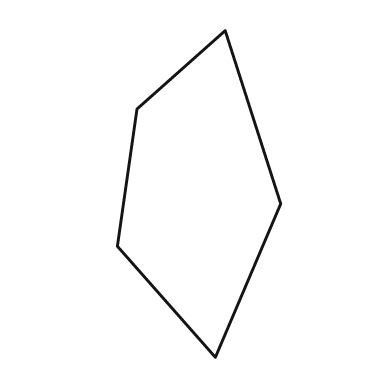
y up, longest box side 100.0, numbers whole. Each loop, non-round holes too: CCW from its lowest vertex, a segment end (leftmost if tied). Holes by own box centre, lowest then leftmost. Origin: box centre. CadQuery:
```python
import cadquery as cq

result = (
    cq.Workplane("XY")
    .moveTo(5.0, -50.0)
    .lineTo(25.0, -3.0)
    .lineTo(8.0, 50.0)
    .lineTo(-19.0, 26.0)
    .lineTo(-25.0, -16.0)
    .close()
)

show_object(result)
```